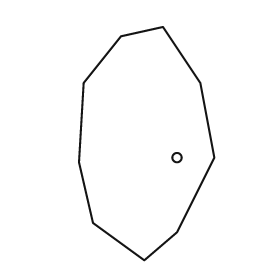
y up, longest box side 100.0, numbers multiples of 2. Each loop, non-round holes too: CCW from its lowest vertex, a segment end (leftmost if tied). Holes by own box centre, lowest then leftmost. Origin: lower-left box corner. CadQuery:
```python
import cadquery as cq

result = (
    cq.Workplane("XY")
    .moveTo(28.0, 0.0)
    .lineTo(42.0, 12.0)
    .lineTo(58.0, 44.0)
    .lineTo(52.0, 76.0)
    .lineTo(36.0, 100.0)
    .lineTo(18.0, 96.0)
    .lineTo(2.0, 76.0)
    .lineTo(0.0, 42.0)
    .lineTo(6.0, 16.0)
    .close()
    .moveTo(42.0, 44.0)
    .circle(2.0)
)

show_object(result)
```